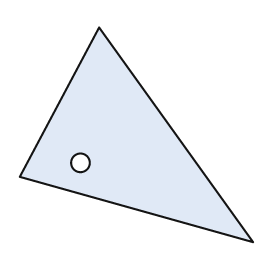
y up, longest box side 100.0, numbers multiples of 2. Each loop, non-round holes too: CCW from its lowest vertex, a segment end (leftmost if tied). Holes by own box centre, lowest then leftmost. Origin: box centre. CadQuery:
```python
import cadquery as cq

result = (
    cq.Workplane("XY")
    .moveTo(50.0, -46.0)
    .lineTo(-16.0, 46.0)
    .lineTo(-50.0, -18.0)
    .close()
    .moveTo(-24.0, -12.0)
    .circle(4.0)
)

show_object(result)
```